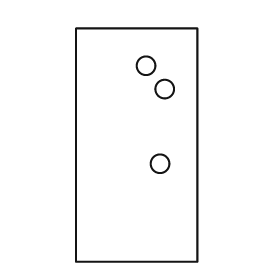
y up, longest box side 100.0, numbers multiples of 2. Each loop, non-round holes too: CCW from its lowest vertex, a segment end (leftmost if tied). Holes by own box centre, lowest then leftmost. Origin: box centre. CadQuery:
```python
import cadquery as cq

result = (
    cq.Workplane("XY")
    .moveTo(-26.0, -50.0)
    .lineTo(26.0, -50.0)
    .lineTo(26.0, 50.0)
    .lineTo(-26.0, 50.0)
    .close()
    .moveTo(10.0, -8.0)
    .circle(4.0)
    .moveTo(12.0, 24.0)
    .circle(4.0)
    .moveTo(4.0, 34.0)
    .circle(4.0)
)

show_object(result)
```